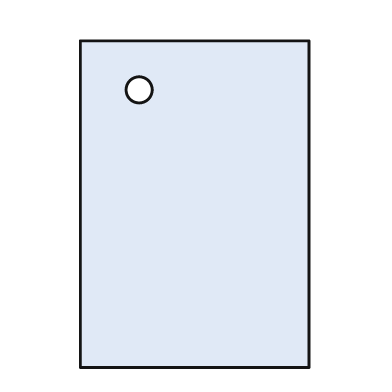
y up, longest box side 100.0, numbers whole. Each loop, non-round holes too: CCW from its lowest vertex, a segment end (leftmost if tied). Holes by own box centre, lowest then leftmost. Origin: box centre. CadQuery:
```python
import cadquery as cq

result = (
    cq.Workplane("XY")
    .moveTo(-35.0, -50.0)
    .lineTo(35.0, -50.0)
    .lineTo(35.0, 50.0)
    .lineTo(-35.0, 50.0)
    .close()
    .moveTo(-17.0, 35.0)
    .circle(4.0)
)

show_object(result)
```